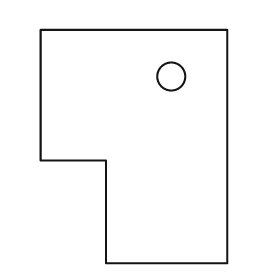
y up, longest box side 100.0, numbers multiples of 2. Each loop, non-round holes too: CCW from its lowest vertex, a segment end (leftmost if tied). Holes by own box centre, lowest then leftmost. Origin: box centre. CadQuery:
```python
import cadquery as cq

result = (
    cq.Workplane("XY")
    .moveTo(-12.0, -50.0)
    .lineTo(40.0, -50.0)
    .lineTo(40.0, 50.0)
    .lineTo(-40.0, 50.0)
    .lineTo(-40.0, -6.0)
    .lineTo(-12.0, -6.0)
    .close()
    .moveTo(16.0, 30.0)
    .circle(6.0)
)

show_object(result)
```